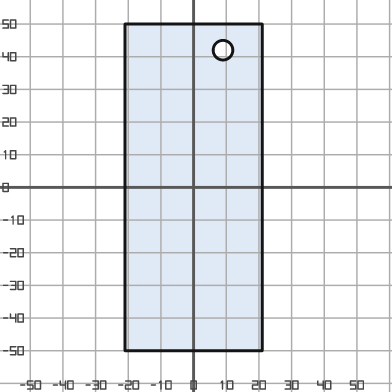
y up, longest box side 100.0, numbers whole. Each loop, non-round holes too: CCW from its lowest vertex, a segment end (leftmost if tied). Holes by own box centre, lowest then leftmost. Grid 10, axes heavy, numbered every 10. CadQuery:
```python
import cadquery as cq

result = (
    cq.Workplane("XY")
    .moveTo(-21.0, -50.0)
    .lineTo(21.0, -50.0)
    .lineTo(21.0, 50.0)
    .lineTo(-21.0, 50.0)
    .close()
    .moveTo(9.0, 42.0)
    .circle(3.0)
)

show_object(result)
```